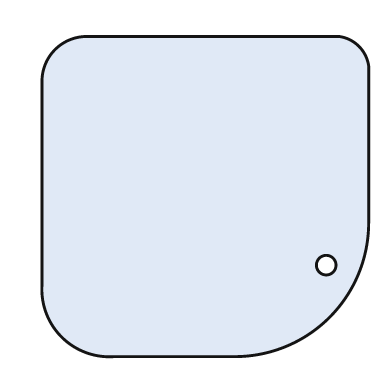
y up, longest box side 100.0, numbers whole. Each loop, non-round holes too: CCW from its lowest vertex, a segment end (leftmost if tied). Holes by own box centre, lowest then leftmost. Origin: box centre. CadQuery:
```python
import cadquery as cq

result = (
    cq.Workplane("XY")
    .moveTo(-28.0, -49.0)
    .lineTo(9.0, -49.0)
    .threePointArc((38.0, -37.0), (50.0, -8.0))
    .lineTo(50.0, 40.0)
    .threePointArc((47.0, 46.0), (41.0, 49.0))
    .lineTo(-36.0, 49.0)
    .threePointArc((-46.0, 45.0), (-50.0, 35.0))
    .lineTo(-50.0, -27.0)
    .threePointArc((-44.0, -43.0), (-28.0, -49.0))
    .close()
    .moveTo(37.0, -21.0)
    .circle(3.0)
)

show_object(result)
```